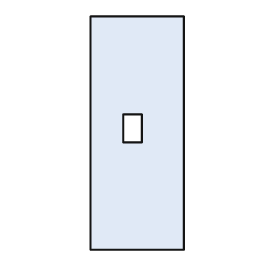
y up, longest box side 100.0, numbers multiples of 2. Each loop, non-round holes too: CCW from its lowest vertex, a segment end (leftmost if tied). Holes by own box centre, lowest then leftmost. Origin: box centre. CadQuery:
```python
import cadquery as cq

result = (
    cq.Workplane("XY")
    .moveTo(-20.0, -50.0)
    .lineTo(20.0, -50.0)
    .lineTo(20.0, 50.0)
    .lineTo(-20.0, 50.0)
    .close()
    .moveTo(-6.0, -4.0)
    .lineTo(2.0, -4.0)
    .lineTo(2.0, 8.0)
    .lineTo(-6.0, 8.0)
    .close()
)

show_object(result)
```